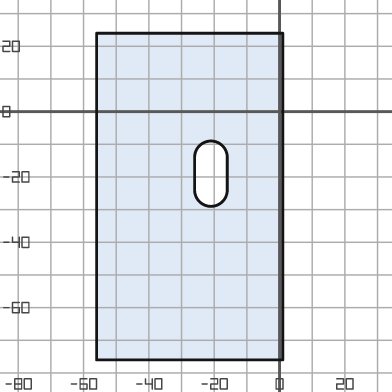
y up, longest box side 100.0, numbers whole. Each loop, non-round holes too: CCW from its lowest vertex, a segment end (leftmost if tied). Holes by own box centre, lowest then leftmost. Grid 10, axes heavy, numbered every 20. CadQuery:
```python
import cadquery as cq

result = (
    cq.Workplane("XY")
    .moveTo(-56.0, -76.0)
    .lineTo(1.0, -76.0)
    .lineTo(1.0, 24.0)
    .lineTo(-56.0, 24.0)
    .close()
    .moveTo(-26.0, -24.0)
    .threePointArc((-21.0, -29.0), (-16.0, -24.0))
    .lineTo(-16.0, -14.0)
    .threePointArc((-21.0, -9.0), (-26.0, -14.0))
    .close()
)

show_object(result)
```